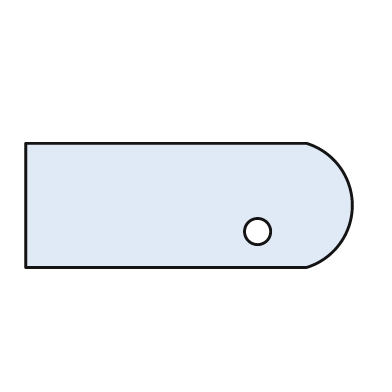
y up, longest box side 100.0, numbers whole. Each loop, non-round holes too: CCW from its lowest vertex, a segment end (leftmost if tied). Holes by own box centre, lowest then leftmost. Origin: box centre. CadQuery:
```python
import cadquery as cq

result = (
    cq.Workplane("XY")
    .moveTo(-50.0, -19.0)
    .lineTo(36.0, -19.0)
    .threePointArc((50.0, 0.0), (36.0, 19.0))
    .lineTo(-50.0, 19.0)
    .close()
    .moveTo(21.0, -8.0)
    .circle(4.0)
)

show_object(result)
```